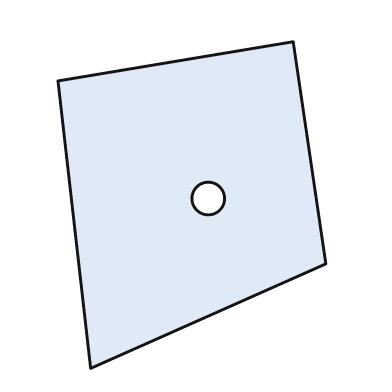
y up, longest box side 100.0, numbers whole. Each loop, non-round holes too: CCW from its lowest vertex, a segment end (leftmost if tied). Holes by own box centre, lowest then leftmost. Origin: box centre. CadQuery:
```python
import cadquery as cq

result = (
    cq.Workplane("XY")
    .moveTo(-31.0, -50.0)
    .lineTo(41.0, -18.0)
    .lineTo(31.0, 50.0)
    .lineTo(-41.0, 38.0)
    .close()
    .moveTo(5.0, 2.0)
    .circle(5.0)
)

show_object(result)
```